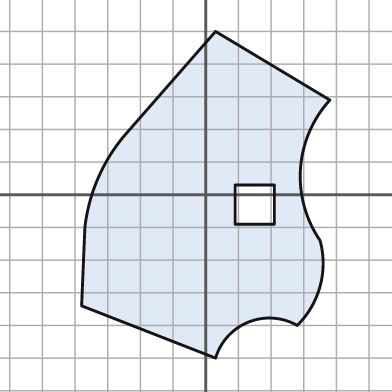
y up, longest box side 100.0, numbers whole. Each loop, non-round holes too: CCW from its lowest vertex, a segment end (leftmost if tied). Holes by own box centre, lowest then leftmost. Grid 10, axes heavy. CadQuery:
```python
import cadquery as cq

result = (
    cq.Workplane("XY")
    .moveTo(3.0, -50.0)
    .threePointArc((13.0, -39.0), (28.0, -40.0))
    .threePointArc((35.0, -28.0), (35.0, -14.0))
    .threePointArc((29.0, 8.0), (38.0, 29.0))
    .lineTo(3.0, 50.0)
    .lineTo(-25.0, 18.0)
    .threePointArc((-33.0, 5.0), (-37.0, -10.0))
    .lineTo(-38.0, -34.0)
    .close()
    .moveTo(9.0, -9.0)
    .lineTo(21.0, -9.0)
    .lineTo(21.0, 3.0)
    .lineTo(9.0, 3.0)
    .close()
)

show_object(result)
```